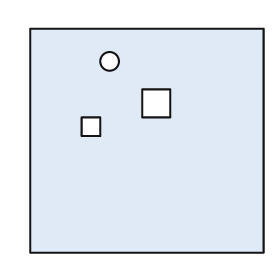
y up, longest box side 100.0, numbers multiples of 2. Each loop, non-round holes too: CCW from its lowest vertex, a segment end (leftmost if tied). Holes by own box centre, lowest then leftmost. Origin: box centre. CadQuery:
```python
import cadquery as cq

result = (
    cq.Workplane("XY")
    .moveTo(-50.0, -48.0)
    .lineTo(50.0, -48.0)
    .lineTo(50.0, 48.0)
    .lineTo(-50.0, 48.0)
    .close()
    .moveTo(-28.0, 2.0)
    .lineTo(-20.0, 2.0)
    .lineTo(-20.0, 10.0)
    .lineTo(-28.0, 10.0)
    .close()
    .moveTo(-2.0, 10.0)
    .lineTo(10.0, 10.0)
    .lineTo(10.0, 22.0)
    .lineTo(-2.0, 22.0)
    .close()
    .moveTo(-16.0, 34.0)
    .circle(4.0)
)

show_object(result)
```